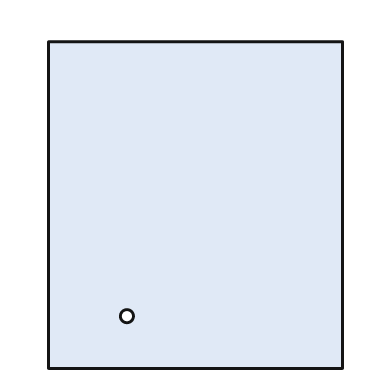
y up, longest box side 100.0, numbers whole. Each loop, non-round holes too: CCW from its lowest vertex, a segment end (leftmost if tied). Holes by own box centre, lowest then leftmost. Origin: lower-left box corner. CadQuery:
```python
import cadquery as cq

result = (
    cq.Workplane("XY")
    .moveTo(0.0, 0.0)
    .lineTo(90.0, 0.0)
    .lineTo(90.0, 100.0)
    .lineTo(0.0, 100.0)
    .close()
    .moveTo(24.0, 16.0)
    .circle(2.0)
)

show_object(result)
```